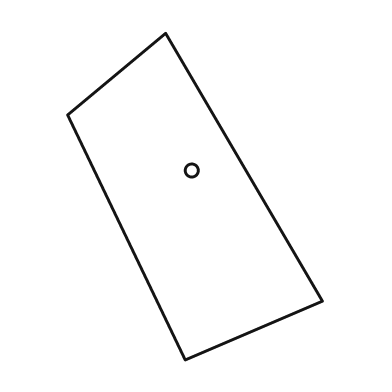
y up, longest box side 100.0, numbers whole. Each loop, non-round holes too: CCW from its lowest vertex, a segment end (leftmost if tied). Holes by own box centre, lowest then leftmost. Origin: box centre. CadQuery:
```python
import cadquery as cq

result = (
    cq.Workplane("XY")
    .moveTo(-3.0, -50.0)
    .lineTo(39.0, -32.0)
    .lineTo(-9.0, 50.0)
    .lineTo(-39.0, 25.0)
    .close()
    .moveTo(-1.0, 8.0)
    .circle(2.0)
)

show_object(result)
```